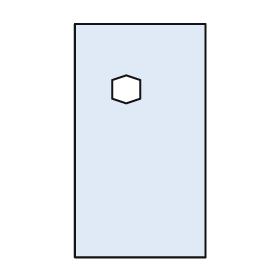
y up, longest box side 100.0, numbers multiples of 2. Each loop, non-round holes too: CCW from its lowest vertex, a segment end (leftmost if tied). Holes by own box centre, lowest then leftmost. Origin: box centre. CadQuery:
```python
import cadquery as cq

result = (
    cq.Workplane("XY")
    .moveTo(-28.0, -50.0)
    .lineTo(28.0, -50.0)
    .lineTo(28.0, 50.0)
    .lineTo(-28.0, 50.0)
    .close()
    .moveTo(-6.0, 16.0)
    .lineTo(0.0, 18.0)
    .lineTo(0.0, 26.0)
    .lineTo(-6.0, 28.0)
    .lineTo(-12.0, 26.0)
    .lineTo(-12.0, 18.0)
    .close()
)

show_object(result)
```